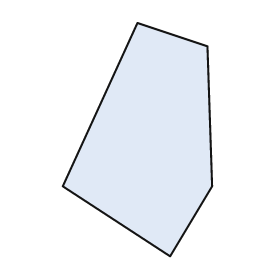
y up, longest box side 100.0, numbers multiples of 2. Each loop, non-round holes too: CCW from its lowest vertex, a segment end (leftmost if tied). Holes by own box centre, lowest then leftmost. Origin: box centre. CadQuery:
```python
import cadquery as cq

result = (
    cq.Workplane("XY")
    .moveTo(14.0, -50.0)
    .lineTo(32.0, -20.0)
    .lineTo(30.0, 40.0)
    .lineTo(0.0, 50.0)
    .lineTo(-32.0, -20.0)
    .close()
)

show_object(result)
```